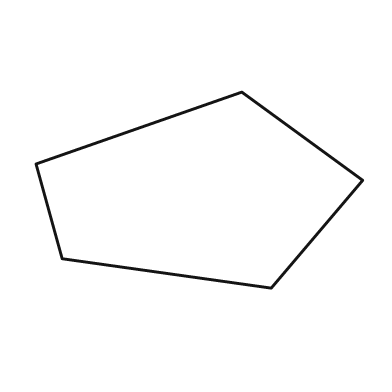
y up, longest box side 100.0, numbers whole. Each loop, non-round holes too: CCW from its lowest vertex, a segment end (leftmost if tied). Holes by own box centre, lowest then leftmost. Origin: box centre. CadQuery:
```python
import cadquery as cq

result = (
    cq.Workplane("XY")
    .moveTo(22.0, -30.0)
    .lineTo(50.0, 3.0)
    .lineTo(13.0, 30.0)
    .lineTo(-50.0, 8.0)
    .lineTo(-42.0, -21.0)
    .close()
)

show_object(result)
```